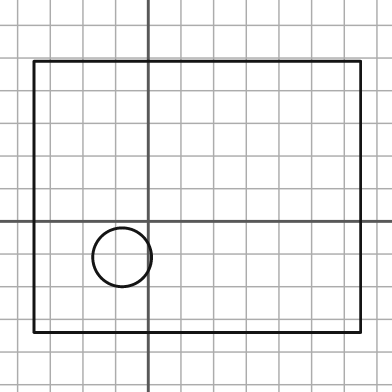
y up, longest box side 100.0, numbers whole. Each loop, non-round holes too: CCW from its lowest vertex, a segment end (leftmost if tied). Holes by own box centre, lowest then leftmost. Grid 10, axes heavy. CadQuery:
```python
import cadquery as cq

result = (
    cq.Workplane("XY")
    .moveTo(-35.0, -34.0)
    .lineTo(65.0, -34.0)
    .lineTo(65.0, 49.0)
    .lineTo(-35.0, 49.0)
    .close()
    .moveTo(-8.0, -11.0)
    .circle(9.0)
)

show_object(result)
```